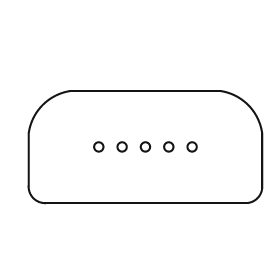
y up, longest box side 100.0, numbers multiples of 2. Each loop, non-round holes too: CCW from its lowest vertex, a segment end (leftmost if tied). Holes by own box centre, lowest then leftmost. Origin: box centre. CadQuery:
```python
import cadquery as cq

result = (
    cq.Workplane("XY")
    .moveTo(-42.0, -24.0)
    .lineTo(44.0, -24.0)
    .threePointArc((48.0, -22.0), (50.0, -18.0))
    .lineTo(50.0, 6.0)
    .threePointArc((44.0, 18.0), (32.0, 24.0))
    .lineTo(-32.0, 24.0)
    .threePointArc((-44.0, 18.0), (-50.0, 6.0))
    .lineTo(-50.0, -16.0)
    .threePointArc((-48.0, -22.0), (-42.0, -24.0))
    .close()
    .moveTo(-20.0, 0.0)
    .circle(2.0)
    .moveTo(-10.0, 0.0)
    .circle(2.0)
    .moveTo(0.0, 0.0)
    .circle(2.0)
    .moveTo(10.0, 0.0)
    .circle(2.0)
    .moveTo(20.0, 0.0)
    .circle(2.0)
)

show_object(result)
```